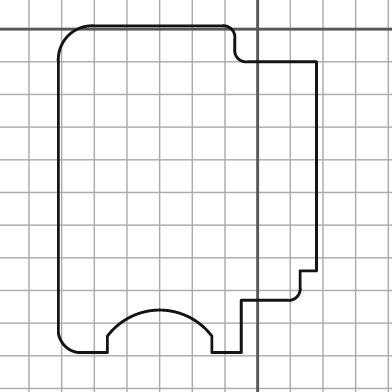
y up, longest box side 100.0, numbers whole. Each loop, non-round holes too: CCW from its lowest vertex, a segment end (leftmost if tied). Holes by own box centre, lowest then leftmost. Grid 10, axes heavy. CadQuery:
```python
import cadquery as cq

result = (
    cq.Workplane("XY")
    .moveTo(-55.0, -99.0)
    .lineTo(-46.0, -99.0)
    .lineTo(-46.0, -94.0)
    .threePointArc((-30.0, -86.0), (-14.0, -94.0))
    .lineTo(-14.0, -99.0)
    .lineTo(-5.0, -99.0)
    .lineTo(-5.0, -83.0)
    .lineTo(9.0, -83.0)
    .threePointArc((12.0, -82.0), (13.0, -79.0))
    .lineTo(13.0, -74.0)
    .lineTo(18.0, -74.0)
    .lineTo(18.0, -10.0)
    .lineTo(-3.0, -10.0)
    .threePointArc((-6.0, -9.0), (-7.0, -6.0))
    .lineTo(-7.0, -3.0)
    .threePointArc((-8.0, 0.0), (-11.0, 1.0))
    .lineTo(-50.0, 1.0)
    .threePointArc((-58.0, -2.0), (-61.0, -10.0))
    .lineTo(-61.0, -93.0)
    .threePointArc((-59.0, -97.0), (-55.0, -99.0))
    .close()
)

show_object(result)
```